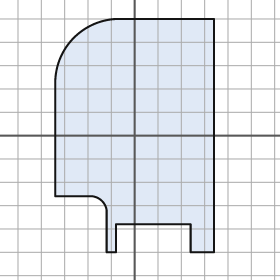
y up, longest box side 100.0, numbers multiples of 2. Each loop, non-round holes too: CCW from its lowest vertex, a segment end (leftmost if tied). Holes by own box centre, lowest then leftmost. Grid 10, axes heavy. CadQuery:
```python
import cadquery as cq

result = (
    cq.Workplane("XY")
    .moveTo(-12.0, -50.0)
    .lineTo(-8.0, -50.0)
    .lineTo(-8.0, -38.0)
    .lineTo(24.0, -38.0)
    .lineTo(24.0, -50.0)
    .lineTo(34.0, -50.0)
    .lineTo(34.0, 50.0)
    .lineTo(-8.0, 50.0)
    .threePointArc((-26.0, 42.0), (-34.0, 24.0))
    .lineTo(-34.0, -26.0)
    .lineTo(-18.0, -26.0)
    .threePointArc((-14.0, -28.0), (-12.0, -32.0))
    .close()
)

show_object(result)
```